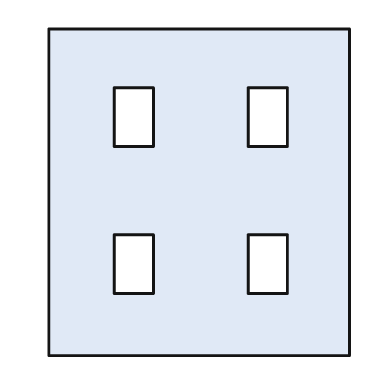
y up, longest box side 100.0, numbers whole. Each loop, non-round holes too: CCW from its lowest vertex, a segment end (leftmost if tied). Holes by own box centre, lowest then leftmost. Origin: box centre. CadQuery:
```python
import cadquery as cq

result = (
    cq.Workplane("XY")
    .moveTo(-46.0, -50.0)
    .lineTo(46.0, -50.0)
    .lineTo(46.0, 50.0)
    .lineTo(-46.0, 50.0)
    .close()
    .moveTo(-26.0, -31.0)
    .lineTo(-14.0, -31.0)
    .lineTo(-14.0, -13.0)
    .lineTo(-26.0, -13.0)
    .close()
    .moveTo(15.0, -31.0)
    .lineTo(27.0, -31.0)
    .lineTo(27.0, -13.0)
    .lineTo(15.0, -13.0)
    .close()
    .moveTo(-26.0, 14.0)
    .lineTo(-14.0, 14.0)
    .lineTo(-14.0, 32.0)
    .lineTo(-26.0, 32.0)
    .close()
    .moveTo(15.0, 14.0)
    .lineTo(27.0, 14.0)
    .lineTo(27.0, 32.0)
    .lineTo(15.0, 32.0)
    .close()
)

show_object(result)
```